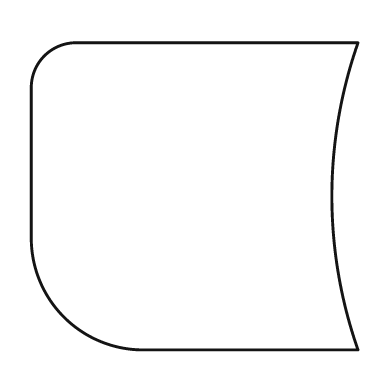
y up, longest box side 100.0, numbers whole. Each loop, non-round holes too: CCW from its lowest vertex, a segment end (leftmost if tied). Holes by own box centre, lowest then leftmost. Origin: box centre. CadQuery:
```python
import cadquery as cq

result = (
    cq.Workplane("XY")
    .moveTo(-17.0, -47.0)
    .lineTo(50.0, -47.0)
    .threePointArc((42.0, 0.0), (50.0, 47.0))
    .lineTo(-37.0, 47.0)
    .threePointArc((-46.0, 43.0), (-50.0, 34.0))
    .lineTo(-50.0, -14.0)
    .threePointArc((-40.0, -37.0), (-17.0, -47.0))
    .close()
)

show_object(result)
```